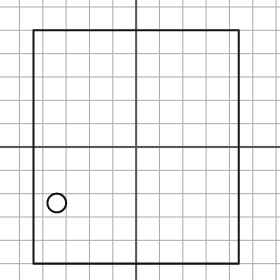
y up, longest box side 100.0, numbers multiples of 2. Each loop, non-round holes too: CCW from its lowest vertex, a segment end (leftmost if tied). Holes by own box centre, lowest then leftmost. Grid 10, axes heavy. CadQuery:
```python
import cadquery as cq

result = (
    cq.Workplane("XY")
    .moveTo(-44.0, -50.0)
    .lineTo(44.0, -50.0)
    .lineTo(44.0, 50.0)
    .lineTo(-44.0, 50.0)
    .close()
    .moveTo(-34.0, -24.0)
    .circle(4.0)
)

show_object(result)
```